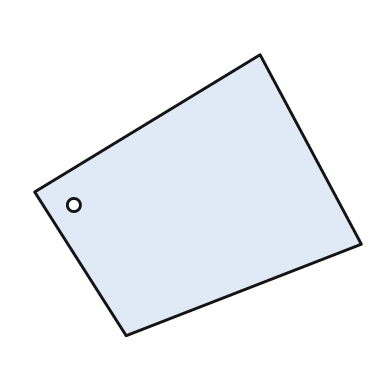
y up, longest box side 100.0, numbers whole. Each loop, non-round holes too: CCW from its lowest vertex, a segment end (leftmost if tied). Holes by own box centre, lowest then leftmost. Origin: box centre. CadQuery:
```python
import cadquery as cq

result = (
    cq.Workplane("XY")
    .moveTo(-22.0, -43.0)
    .lineTo(50.0, -15.0)
    .lineTo(19.0, 43.0)
    .lineTo(-50.0, 1.0)
    .close()
    .moveTo(-38.0, -3.0)
    .circle(2.0)
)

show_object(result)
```